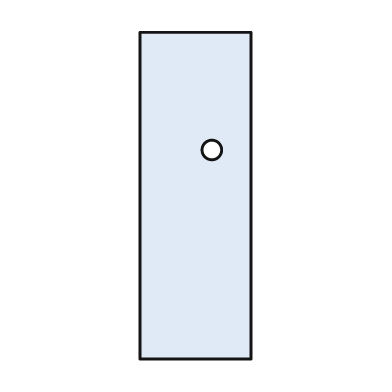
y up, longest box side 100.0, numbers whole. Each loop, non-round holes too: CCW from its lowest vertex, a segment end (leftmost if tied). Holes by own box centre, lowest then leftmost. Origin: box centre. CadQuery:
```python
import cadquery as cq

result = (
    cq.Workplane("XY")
    .moveTo(-17.0, -50.0)
    .lineTo(17.0, -50.0)
    .lineTo(17.0, 50.0)
    .lineTo(-17.0, 50.0)
    .close()
    .moveTo(5.0, 14.0)
    .circle(3.0)
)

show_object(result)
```